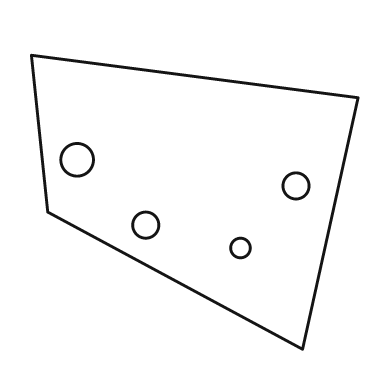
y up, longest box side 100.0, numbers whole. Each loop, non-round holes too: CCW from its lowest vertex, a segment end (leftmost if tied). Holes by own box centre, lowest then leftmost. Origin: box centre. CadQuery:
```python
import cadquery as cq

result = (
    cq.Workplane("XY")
    .moveTo(33.0, -45.0)
    .lineTo(50.0, 32.0)
    .lineTo(-50.0, 45.0)
    .lineTo(-45.0, -3.0)
    .close()
    .moveTo(14.0, -14.0)
    .circle(3.0)
    .moveTo(-15.0, -7.0)
    .circle(4.0)
    .moveTo(31.0, 5.0)
    .circle(4.0)
    .moveTo(-36.0, 13.0)
    .circle(5.0)
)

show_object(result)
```